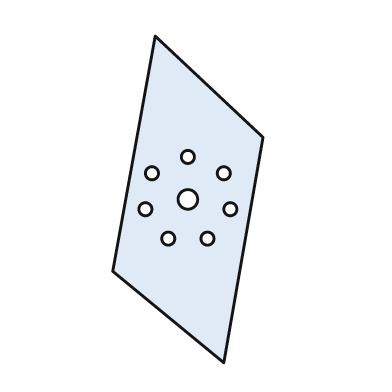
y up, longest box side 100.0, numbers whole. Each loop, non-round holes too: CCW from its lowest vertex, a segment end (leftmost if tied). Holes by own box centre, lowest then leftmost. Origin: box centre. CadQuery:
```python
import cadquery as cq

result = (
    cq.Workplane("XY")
    .moveTo(11.0, -50.0)
    .lineTo(23.0, 19.0)
    .lineTo(-10.0, 50.0)
    .lineTo(-23.0, -22.0)
    .close()
    .moveTo(-6.0, -12.0)
    .circle(2.0)
    .moveTo(6.0, -12.0)
    .circle(2.0)
    .moveTo(-13.0, -3.0)
    .circle(2.0)
    .moveTo(13.0, -3.0)
    .circle(2.0)
    .moveTo(0.0, 0.0)
    .circle(3.0)
    .moveTo(-11.0, 8.0)
    .circle(2.0)
    .moveTo(11.0, 8.0)
    .circle(2.0)
    .moveTo(0.0, 13.0)
    .circle(2.0)
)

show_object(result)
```